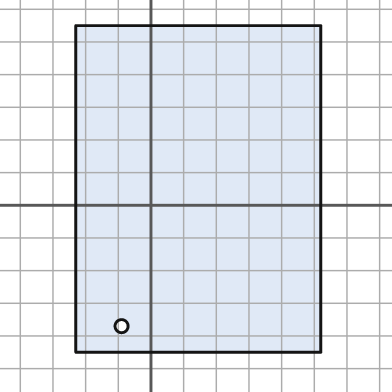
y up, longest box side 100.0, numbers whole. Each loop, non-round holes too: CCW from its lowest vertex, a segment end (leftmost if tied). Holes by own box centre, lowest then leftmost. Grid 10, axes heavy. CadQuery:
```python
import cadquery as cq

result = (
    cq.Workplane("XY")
    .moveTo(-23.0, -45.0)
    .lineTo(52.0, -45.0)
    .lineTo(52.0, 55.0)
    .lineTo(-23.0, 55.0)
    .close()
    .moveTo(-9.0, -37.0)
    .circle(2.0)
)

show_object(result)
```